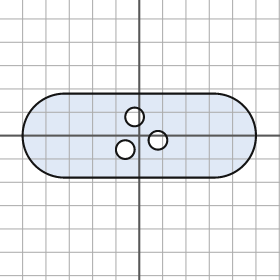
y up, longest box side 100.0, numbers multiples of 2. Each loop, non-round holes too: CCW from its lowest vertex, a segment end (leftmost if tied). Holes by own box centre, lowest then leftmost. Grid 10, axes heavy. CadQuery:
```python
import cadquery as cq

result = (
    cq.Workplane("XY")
    .moveTo(-32.0, -18.0)
    .lineTo(32.0, -18.0)
    .threePointArc((50.0, 0.0), (32.0, 18.0))
    .lineTo(-32.0, 18.0)
    .threePointArc((-50.0, 0.0), (-32.0, -18.0))
    .close()
    .moveTo(-6.0, -6.0)
    .circle(4.0)
    .moveTo(8.0, -2.0)
    .circle(4.0)
    .moveTo(-2.0, 8.0)
    .circle(4.0)
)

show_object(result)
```